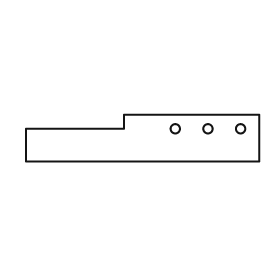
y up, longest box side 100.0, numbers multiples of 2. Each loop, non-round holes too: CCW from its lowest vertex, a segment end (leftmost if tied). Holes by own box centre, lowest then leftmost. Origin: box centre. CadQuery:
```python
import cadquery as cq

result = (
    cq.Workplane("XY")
    .moveTo(-50.0, -10.0)
    .lineTo(50.0, -10.0)
    .lineTo(50.0, 10.0)
    .lineTo(-8.0, 10.0)
    .lineTo(-8.0, 4.0)
    .lineTo(-50.0, 4.0)
    .close()
    .moveTo(14.0, 4.0)
    .circle(2.0)
    .moveTo(28.0, 4.0)
    .circle(2.0)
    .moveTo(42.0, 4.0)
    .circle(2.0)
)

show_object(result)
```